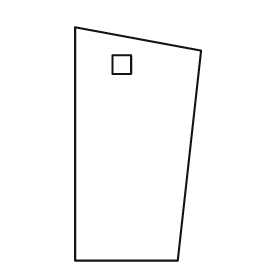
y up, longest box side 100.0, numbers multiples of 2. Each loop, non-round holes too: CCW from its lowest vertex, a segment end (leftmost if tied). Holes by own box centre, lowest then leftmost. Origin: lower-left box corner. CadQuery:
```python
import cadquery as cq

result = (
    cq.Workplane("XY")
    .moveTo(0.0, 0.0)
    .lineTo(44.0, 0.0)
    .lineTo(54.0, 90.0)
    .lineTo(0.0, 100.0)
    .close()
    .moveTo(16.0, 80.0)
    .lineTo(24.0, 80.0)
    .lineTo(24.0, 88.0)
    .lineTo(16.0, 88.0)
    .close()
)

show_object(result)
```